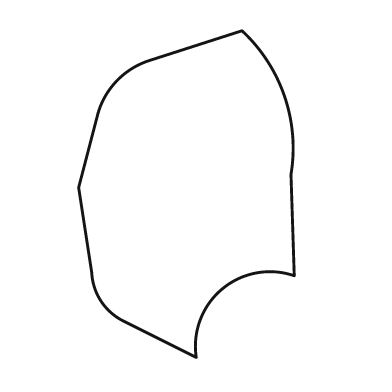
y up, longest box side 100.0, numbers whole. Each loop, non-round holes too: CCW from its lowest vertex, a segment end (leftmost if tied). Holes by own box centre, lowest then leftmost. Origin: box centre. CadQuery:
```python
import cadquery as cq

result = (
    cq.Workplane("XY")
    .moveTo(3.0, -50.0)
    .threePointArc((11.0, -29.0), (33.0, -25.0))
    .lineTo(32.0, 6.0)
    .threePointArc((30.0, 30.0), (17.0, 50.0))
    .lineTo(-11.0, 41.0)
    .threePointArc((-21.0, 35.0), (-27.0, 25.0))
    .lineTo(-33.0, 2.0)
    .lineTo(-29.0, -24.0)
    .threePointArc((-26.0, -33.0), (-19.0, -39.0))
    .close()
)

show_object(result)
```